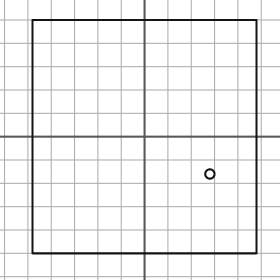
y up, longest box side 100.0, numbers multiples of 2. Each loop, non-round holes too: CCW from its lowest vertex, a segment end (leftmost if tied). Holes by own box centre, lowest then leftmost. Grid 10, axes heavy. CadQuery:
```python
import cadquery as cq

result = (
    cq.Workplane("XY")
    .moveTo(-48.0, -50.0)
    .lineTo(48.0, -50.0)
    .lineTo(48.0, 50.0)
    .lineTo(-48.0, 50.0)
    .close()
    .moveTo(28.0, -16.0)
    .circle(2.0)
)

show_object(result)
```